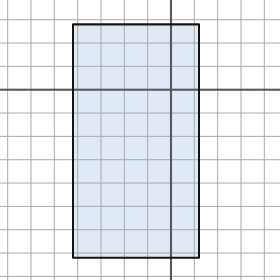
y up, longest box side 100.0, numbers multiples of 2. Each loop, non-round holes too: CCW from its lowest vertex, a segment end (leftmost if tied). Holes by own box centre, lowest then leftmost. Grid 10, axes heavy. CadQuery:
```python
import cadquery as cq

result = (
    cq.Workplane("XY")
    .moveTo(-42.0, -72.0)
    .lineTo(12.0, -72.0)
    .lineTo(12.0, 28.0)
    .lineTo(-42.0, 28.0)
    .close()
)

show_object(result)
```